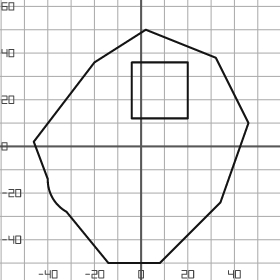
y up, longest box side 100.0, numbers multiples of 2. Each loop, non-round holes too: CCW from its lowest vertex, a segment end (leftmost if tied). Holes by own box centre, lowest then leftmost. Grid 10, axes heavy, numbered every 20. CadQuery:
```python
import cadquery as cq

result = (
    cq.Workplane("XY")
    .moveTo(-14.0, -50.0)
    .lineTo(8.0, -50.0)
    .lineTo(34.0, -24.0)
    .lineTo(46.0, 10.0)
    .lineTo(32.0, 38.0)
    .lineTo(2.0, 50.0)
    .lineTo(-20.0, 36.0)
    .lineTo(-46.0, 2.0)
    .lineTo(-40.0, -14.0)
    .threePointArc((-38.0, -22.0), (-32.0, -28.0))
    .close()
    .moveTo(-4.0, 12.0)
    .lineTo(20.0, 12.0)
    .lineTo(20.0, 36.0)
    .lineTo(-4.0, 36.0)
    .close()
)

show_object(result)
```